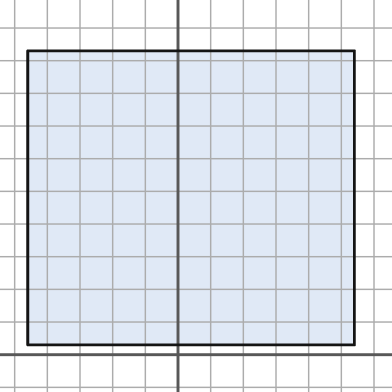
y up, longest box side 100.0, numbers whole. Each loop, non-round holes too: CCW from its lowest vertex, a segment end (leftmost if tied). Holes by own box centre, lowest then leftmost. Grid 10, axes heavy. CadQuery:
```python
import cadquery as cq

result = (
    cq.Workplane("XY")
    .moveTo(-46.0, 3.0)
    .lineTo(54.0, 3.0)
    .lineTo(54.0, 93.0)
    .lineTo(-46.0, 93.0)
    .close()
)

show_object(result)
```